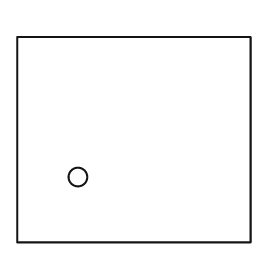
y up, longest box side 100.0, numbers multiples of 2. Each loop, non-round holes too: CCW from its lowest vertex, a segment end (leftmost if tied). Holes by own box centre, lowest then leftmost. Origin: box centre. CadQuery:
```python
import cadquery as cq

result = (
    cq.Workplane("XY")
    .moveTo(-50.0, -44.0)
    .lineTo(50.0, -44.0)
    .lineTo(50.0, 44.0)
    .lineTo(-50.0, 44.0)
    .close()
    .moveTo(-24.0, -16.0)
    .circle(4.0)
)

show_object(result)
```